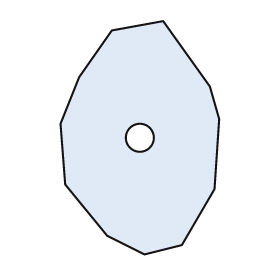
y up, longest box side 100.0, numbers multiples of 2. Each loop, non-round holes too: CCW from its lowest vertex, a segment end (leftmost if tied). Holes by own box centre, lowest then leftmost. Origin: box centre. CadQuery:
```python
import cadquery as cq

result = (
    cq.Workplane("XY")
    .moveTo(2.0, -50.0)
    .lineTo(18.0, -46.0)
    .lineTo(32.0, -22.0)
    .lineTo(34.0, 8.0)
    .lineTo(30.0, 22.0)
    .lineTo(10.0, 50.0)
    .lineTo(-12.0, 46.0)
    .lineTo(-26.0, 26.0)
    .lineTo(-34.0, 6.0)
    .lineTo(-32.0, -20.0)
    .lineTo(-14.0, -42.0)
    .close()
    .moveTo(0.0, 0.0)
    .circle(6.0)
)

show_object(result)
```